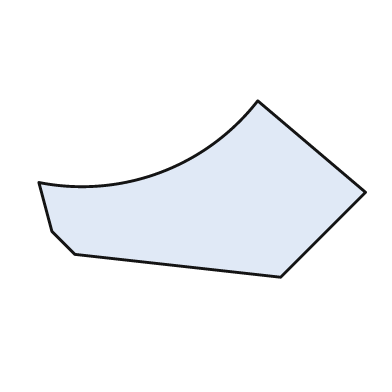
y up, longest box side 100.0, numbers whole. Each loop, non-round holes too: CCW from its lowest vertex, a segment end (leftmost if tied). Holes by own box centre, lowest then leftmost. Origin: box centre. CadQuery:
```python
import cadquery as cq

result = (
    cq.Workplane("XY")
    .moveTo(24.0, -27.0)
    .lineTo(50.0, -1.0)
    .lineTo(17.0, 27.0)
    .threePointArc((-13.0, 5.0), (-50.0, 2.0))
    .lineTo(-46.0, -13.0)
    .lineTo(-39.0, -20.0)
    .close()
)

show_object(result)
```